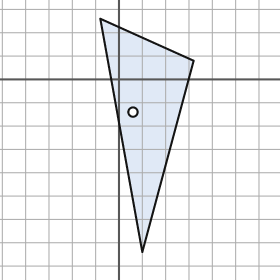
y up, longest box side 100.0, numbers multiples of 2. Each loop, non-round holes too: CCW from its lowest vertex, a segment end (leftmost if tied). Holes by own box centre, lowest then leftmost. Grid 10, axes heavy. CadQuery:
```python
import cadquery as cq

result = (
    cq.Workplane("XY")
    .moveTo(10.0, -74.0)
    .lineTo(32.0, 8.0)
    .lineTo(-8.0, 26.0)
    .close()
    .moveTo(6.0, -14.0)
    .circle(2.0)
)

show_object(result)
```